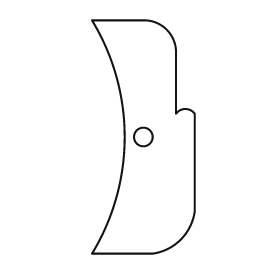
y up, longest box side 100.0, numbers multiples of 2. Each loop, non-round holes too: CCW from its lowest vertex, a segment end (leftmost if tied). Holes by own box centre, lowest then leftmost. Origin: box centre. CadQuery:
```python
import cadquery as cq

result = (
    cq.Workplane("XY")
    .moveTo(-22.0, -50.0)
    .lineTo(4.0, -50.0)
    .threePointArc((16.0, -44.0), (22.0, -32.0))
    .lineTo(22.0, 10.0)
    .threePointArc((18.0, 12.0), (14.0, 10.0))
    .lineTo(14.0, 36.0)
    .threePointArc((10.0, 46.0), (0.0, 50.0))
    .lineTo(-22.0, 50.0)
    .threePointArc((-8.0, 0.0), (-22.0, -50.0))
    .close()
    .moveTo(0.0, 0.0)
    .circle(4.0)
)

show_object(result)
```